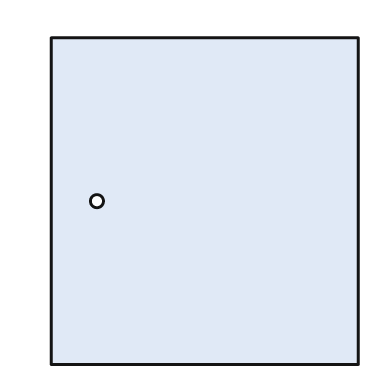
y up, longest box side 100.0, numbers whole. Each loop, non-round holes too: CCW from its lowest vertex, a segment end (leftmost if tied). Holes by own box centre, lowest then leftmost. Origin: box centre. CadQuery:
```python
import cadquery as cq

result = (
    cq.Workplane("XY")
    .moveTo(-47.0, -50.0)
    .lineTo(47.0, -50.0)
    .lineTo(47.0, 50.0)
    .lineTo(-47.0, 50.0)
    .close()
    .moveTo(-33.0, 0.0)
    .circle(2.0)
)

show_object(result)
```